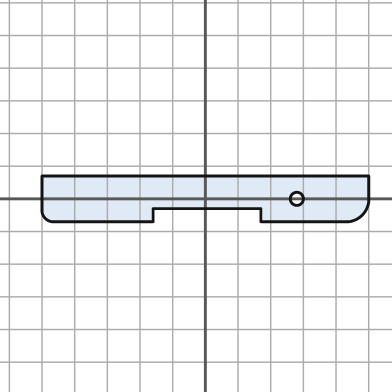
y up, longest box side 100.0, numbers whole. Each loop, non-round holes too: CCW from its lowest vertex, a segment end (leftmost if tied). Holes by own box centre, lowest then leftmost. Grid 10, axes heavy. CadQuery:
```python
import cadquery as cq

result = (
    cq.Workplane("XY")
    .moveTo(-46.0, -7.0)
    .lineTo(-16.0, -7.0)
    .lineTo(-16.0, -3.0)
    .lineTo(17.0, -3.0)
    .lineTo(17.0, -7.0)
    .lineTo(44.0, -7.0)
    .threePointArc((48.0, -5.0), (50.0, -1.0))
    .lineTo(50.0, 7.0)
    .lineTo(-50.0, 7.0)
    .lineTo(-50.0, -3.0)
    .threePointArc((-49.0, -6.0), (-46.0, -7.0))
    .close()
    .moveTo(28.0, 0.0)
    .circle(2.0)
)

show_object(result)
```